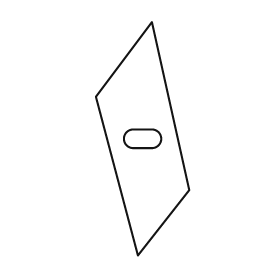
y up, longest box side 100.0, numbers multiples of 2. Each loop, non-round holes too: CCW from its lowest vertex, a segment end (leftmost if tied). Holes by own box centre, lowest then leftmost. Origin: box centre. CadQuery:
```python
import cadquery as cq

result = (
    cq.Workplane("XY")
    .moveTo(-2.0, -50.0)
    .lineTo(20.0, -22.0)
    .lineTo(4.0, 50.0)
    .lineTo(-20.0, 18.0)
    .close()
    .moveTo(-4.0, -4.0)
    .lineTo(4.0, -4.0)
    .threePointArc((8.0, 0.0), (4.0, 4.0))
    .lineTo(-4.0, 4.0)
    .threePointArc((-8.0, 0.0), (-4.0, -4.0))
    .close()
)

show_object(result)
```